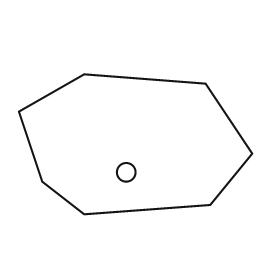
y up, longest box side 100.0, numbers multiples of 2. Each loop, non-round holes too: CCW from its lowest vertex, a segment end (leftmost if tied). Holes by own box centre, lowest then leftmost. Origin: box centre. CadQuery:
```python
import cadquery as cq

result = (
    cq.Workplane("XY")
    .moveTo(-22.0, -30.0)
    .lineTo(32.0, -26.0)
    .lineTo(50.0, -4.0)
    .lineTo(30.0, 26.0)
    .lineTo(-22.0, 30.0)
    .lineTo(-50.0, 14.0)
    .lineTo(-40.0, -16.0)
    .close()
    .moveTo(-4.0, -12.0)
    .circle(4.0)
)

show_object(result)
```